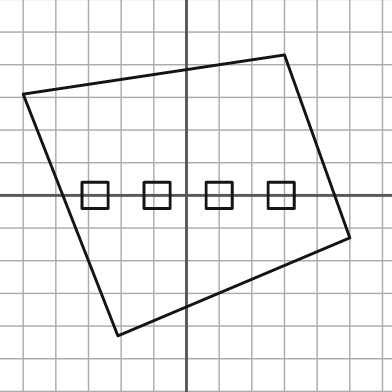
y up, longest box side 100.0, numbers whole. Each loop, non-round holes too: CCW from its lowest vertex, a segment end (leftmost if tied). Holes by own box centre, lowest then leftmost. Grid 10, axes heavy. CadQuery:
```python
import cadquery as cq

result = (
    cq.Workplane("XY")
    .moveTo(-21.0, -43.0)
    .lineTo(50.0, -13.0)
    .lineTo(30.0, 43.0)
    .lineTo(-50.0, 31.0)
    .close()
    .moveTo(-32.0, -4.0)
    .lineTo(-24.0, -4.0)
    .lineTo(-24.0, 4.0)
    .lineTo(-32.0, 4.0)
    .close()
    .moveTo(-13.0, -4.0)
    .lineTo(-5.0, -4.0)
    .lineTo(-5.0, 4.0)
    .lineTo(-13.0, 4.0)
    .close()
    .moveTo(6.0, -4.0)
    .lineTo(14.0, -4.0)
    .lineTo(14.0, 4.0)
    .lineTo(6.0, 4.0)
    .close()
    .moveTo(25.0, -4.0)
    .lineTo(33.0, -4.0)
    .lineTo(33.0, 4.0)
    .lineTo(25.0, 4.0)
    .close()
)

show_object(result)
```